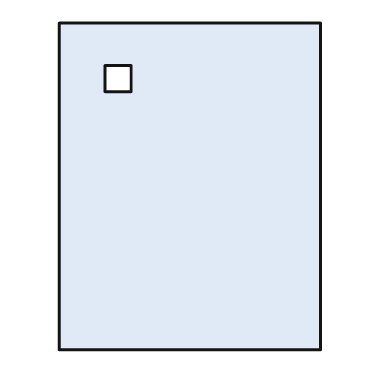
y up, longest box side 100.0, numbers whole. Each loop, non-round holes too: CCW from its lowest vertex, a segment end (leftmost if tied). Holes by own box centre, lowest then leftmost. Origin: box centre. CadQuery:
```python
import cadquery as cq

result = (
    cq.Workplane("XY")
    .moveTo(-40.0, -50.0)
    .lineTo(40.0, -50.0)
    .lineTo(40.0, 50.0)
    .lineTo(-40.0, 50.0)
    .close()
    .moveTo(-26.0, 29.0)
    .lineTo(-18.0, 29.0)
    .lineTo(-18.0, 37.0)
    .lineTo(-26.0, 37.0)
    .close()
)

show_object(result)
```